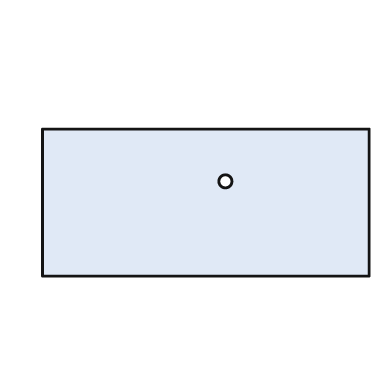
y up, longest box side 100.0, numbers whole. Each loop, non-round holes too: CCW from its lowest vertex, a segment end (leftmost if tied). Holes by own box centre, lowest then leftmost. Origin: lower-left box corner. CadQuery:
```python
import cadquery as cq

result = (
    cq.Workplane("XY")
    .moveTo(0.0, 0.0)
    .lineTo(100.0, 0.0)
    .lineTo(100.0, 45.0)
    .lineTo(0.0, 45.0)
    .close()
    .moveTo(56.0, 29.0)
    .circle(2.0)
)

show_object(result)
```